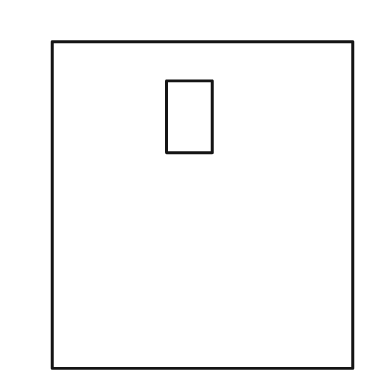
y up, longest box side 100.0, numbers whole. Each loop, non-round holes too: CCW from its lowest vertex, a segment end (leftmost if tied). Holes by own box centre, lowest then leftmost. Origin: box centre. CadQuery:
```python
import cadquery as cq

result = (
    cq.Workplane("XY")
    .moveTo(-46.0, -50.0)
    .lineTo(46.0, -50.0)
    .lineTo(46.0, 50.0)
    .lineTo(-46.0, 50.0)
    .close()
    .moveTo(-11.0, 16.0)
    .lineTo(3.0, 16.0)
    .lineTo(3.0, 38.0)
    .lineTo(-11.0, 38.0)
    .close()
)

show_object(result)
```